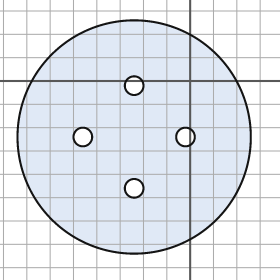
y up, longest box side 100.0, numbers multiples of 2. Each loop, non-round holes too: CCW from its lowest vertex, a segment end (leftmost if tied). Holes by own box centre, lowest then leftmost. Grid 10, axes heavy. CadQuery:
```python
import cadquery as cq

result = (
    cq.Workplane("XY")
    .moveTo(-24.0, -24.0)
    .circle(50.0)
    .moveTo(-24.0, -46.0)
    .circle(4.0)
    .moveTo(-46.0, -24.0)
    .circle(4.0)
    .moveTo(-2.0, -24.0)
    .circle(4.0)
    .moveTo(-24.0, -2.0)
    .circle(4.0)
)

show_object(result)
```